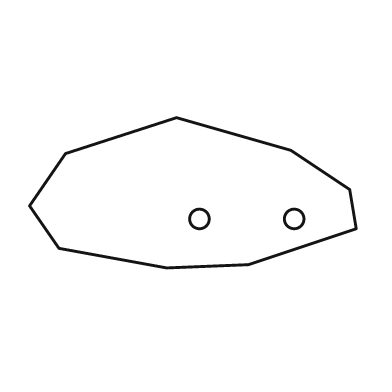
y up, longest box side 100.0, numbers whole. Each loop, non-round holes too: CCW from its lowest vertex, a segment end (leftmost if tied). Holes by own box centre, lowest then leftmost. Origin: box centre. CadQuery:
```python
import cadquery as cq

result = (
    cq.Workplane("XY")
    .moveTo(-8.0, -23.0)
    .lineTo(17.0, -22.0)
    .lineTo(50.0, -11.0)
    .lineTo(48.0, 1.0)
    .lineTo(30.0, 13.0)
    .lineTo(-5.0, 23.0)
    .lineTo(-39.0, 12.0)
    .lineTo(-50.0, -4.0)
    .lineTo(-41.0, -17.0)
    .close()
    .moveTo(2.0, -8.0)
    .circle(3.0)
    .moveTo(31.0, -8.0)
    .circle(3.0)
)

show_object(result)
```